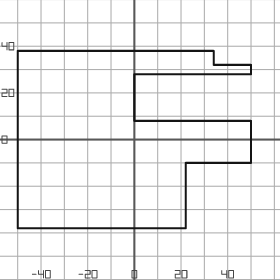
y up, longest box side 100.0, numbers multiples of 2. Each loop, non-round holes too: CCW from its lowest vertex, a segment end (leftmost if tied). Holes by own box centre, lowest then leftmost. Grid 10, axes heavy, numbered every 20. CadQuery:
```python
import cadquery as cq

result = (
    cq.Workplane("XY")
    .moveTo(-50.0, -38.0)
    .lineTo(22.0, -38.0)
    .lineTo(22.0, -10.0)
    .lineTo(50.0, -10.0)
    .lineTo(50.0, 8.0)
    .lineTo(0.0, 8.0)
    .lineTo(0.0, 28.0)
    .lineTo(50.0, 28.0)
    .lineTo(50.0, 32.0)
    .lineTo(34.0, 32.0)
    .lineTo(34.0, 38.0)
    .lineTo(-50.0, 38.0)
    .close()
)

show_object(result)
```